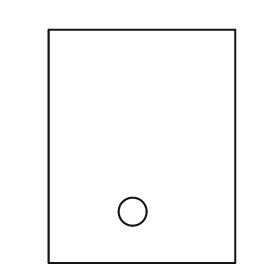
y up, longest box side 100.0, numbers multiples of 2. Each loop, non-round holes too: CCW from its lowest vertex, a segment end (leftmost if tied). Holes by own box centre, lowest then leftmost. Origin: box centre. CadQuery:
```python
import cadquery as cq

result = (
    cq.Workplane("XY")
    .moveTo(-40.0, -50.0)
    .lineTo(40.0, -50.0)
    .lineTo(40.0, 50.0)
    .lineTo(-40.0, 50.0)
    .close()
    .moveTo(-4.0, -28.0)
    .circle(6.0)
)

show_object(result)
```